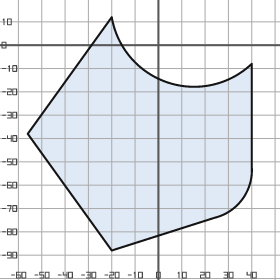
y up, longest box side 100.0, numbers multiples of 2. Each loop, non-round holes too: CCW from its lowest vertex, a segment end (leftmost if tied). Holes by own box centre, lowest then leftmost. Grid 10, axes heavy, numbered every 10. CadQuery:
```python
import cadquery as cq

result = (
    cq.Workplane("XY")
    .moveTo(-20.0, -88.0)
    .lineTo(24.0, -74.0)
    .threePointArc((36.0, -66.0), (40.0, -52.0))
    .lineTo(40.0, -8.0)
    .threePointArc((4.0, -16.0), (-20.0, 12.0))
    .lineTo(-56.0, -38.0)
    .close()
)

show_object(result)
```